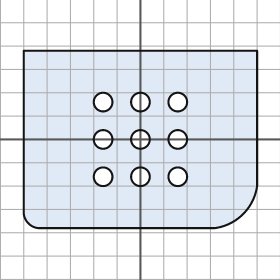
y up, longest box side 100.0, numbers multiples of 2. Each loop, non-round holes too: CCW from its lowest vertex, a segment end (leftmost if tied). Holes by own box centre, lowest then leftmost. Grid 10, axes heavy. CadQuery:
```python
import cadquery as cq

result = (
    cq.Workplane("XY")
    .moveTo(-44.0, -38.0)
    .lineTo(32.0, -38.0)
    .threePointArc((44.0, -32.0), (50.0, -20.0))
    .lineTo(50.0, 38.0)
    .lineTo(-50.0, 38.0)
    .lineTo(-50.0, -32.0)
    .threePointArc((-48.0, -36.0), (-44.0, -38.0))
    .close()
    .moveTo(-16.0, -16.0)
    .circle(4.0)
    .moveTo(0.0, -16.0)
    .circle(4.0)
    .moveTo(16.0, -16.0)
    .circle(4.0)
    .moveTo(-16.0, 0.0)
    .circle(4.0)
    .moveTo(0.0, 0.0)
    .circle(4.0)
    .moveTo(16.0, 0.0)
    .circle(4.0)
    .moveTo(-16.0, 16.0)
    .circle(4.0)
    .moveTo(0.0, 16.0)
    .circle(4.0)
    .moveTo(16.0, 16.0)
    .circle(4.0)
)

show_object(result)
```